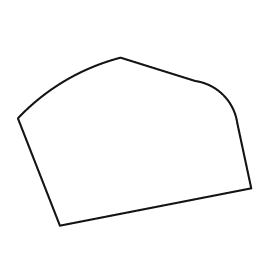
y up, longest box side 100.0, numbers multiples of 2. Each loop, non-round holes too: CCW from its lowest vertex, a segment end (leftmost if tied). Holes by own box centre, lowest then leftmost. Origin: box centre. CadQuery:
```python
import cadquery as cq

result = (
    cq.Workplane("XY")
    .moveTo(-32.0, -36.0)
    .lineTo(50.0, -20.0)
    .lineTo(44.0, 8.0)
    .threePointArc((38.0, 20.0), (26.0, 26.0))
    .lineTo(-6.0, 36.0)
    .threePointArc((-30.0, 26.0), (-50.0, 10.0))
    .close()
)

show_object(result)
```